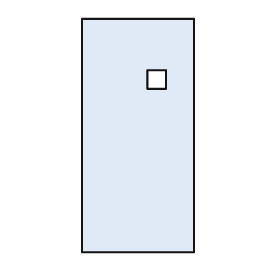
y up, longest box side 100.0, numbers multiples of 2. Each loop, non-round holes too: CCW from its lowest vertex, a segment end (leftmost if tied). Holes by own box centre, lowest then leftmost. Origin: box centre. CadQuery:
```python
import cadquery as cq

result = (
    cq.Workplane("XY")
    .moveTo(-24.0, -50.0)
    .lineTo(24.0, -50.0)
    .lineTo(24.0, 50.0)
    .lineTo(-24.0, 50.0)
    .close()
    .moveTo(4.0, 20.0)
    .lineTo(12.0, 20.0)
    .lineTo(12.0, 28.0)
    .lineTo(4.0, 28.0)
    .close()
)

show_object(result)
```